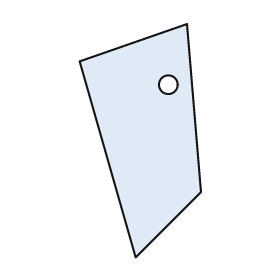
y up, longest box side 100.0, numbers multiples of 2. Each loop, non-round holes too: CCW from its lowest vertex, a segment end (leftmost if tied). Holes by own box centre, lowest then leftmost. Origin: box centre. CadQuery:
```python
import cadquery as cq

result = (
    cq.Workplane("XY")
    .moveTo(-2.0, -50.0)
    .lineTo(26.0, -22.0)
    .lineTo(20.0, 50.0)
    .lineTo(-26.0, 34.0)
    .close()
    .moveTo(12.0, 24.0)
    .circle(4.0)
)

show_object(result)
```